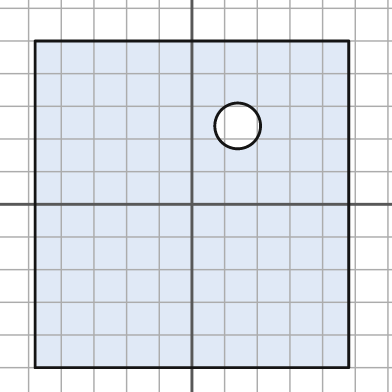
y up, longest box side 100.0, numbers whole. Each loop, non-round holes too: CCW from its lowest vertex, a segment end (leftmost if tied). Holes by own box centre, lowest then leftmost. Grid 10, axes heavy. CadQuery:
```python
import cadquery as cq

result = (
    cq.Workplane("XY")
    .moveTo(-48.0, -50.0)
    .lineTo(48.0, -50.0)
    .lineTo(48.0, 50.0)
    .lineTo(-48.0, 50.0)
    .close()
    .moveTo(14.0, 24.0)
    .circle(7.0)
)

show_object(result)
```